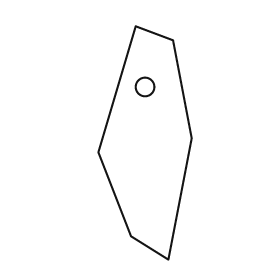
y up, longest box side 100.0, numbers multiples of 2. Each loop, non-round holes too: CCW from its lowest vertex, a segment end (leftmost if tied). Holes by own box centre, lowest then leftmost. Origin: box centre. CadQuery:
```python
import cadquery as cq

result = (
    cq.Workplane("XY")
    .moveTo(10.0, -50.0)
    .lineTo(20.0, 2.0)
    .lineTo(12.0, 44.0)
    .lineTo(-4.0, 50.0)
    .lineTo(-20.0, -4.0)
    .lineTo(-6.0, -40.0)
    .close()
    .moveTo(0.0, 24.0)
    .circle(4.0)
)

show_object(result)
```